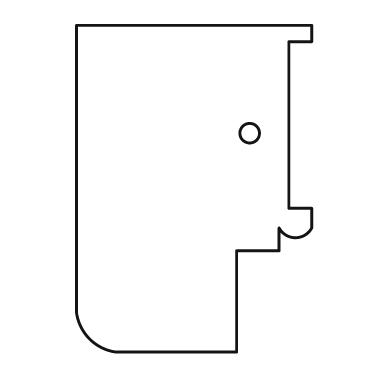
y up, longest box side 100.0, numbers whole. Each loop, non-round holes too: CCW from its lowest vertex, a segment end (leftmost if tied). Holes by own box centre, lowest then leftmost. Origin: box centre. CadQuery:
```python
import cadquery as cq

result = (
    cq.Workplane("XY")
    .moveTo(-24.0, -50.0)
    .lineTo(13.0, -50.0)
    .lineTo(13.0, -19.0)
    .lineTo(26.0, -19.0)
    .lineTo(26.0, -12.0)
    .threePointArc((31.0, -15.0), (36.0, -12.0))
    .lineTo(36.0, -6.0)
    .lineTo(29.0, -6.0)
    .lineTo(29.0, 45.0)
    .lineTo(36.0, 45.0)
    .lineTo(36.0, 50.0)
    .lineTo(-36.0, 50.0)
    .lineTo(-36.0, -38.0)
    .threePointArc((-32.0, -46.0), (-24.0, -50.0))
    .close()
    .moveTo(17.0, 17.0)
    .circle(3.0)
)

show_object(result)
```